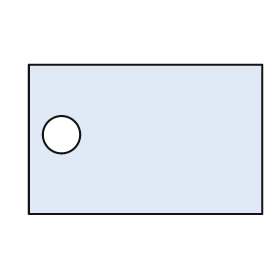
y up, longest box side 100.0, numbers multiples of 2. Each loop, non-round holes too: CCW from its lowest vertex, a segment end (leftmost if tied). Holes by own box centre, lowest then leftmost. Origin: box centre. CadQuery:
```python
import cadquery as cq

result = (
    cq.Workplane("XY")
    .moveTo(-50.0, -32.0)
    .lineTo(50.0, -32.0)
    .lineTo(50.0, 32.0)
    .lineTo(-50.0, 32.0)
    .close()
    .moveTo(-36.0, 2.0)
    .circle(8.0)
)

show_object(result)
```